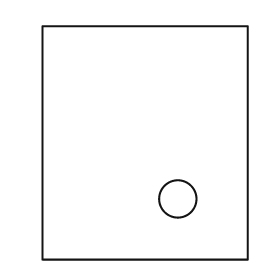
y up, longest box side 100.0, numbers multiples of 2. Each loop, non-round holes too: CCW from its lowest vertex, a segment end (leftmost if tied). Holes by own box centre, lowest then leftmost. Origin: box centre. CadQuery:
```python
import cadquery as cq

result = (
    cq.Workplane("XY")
    .moveTo(-44.0, -50.0)
    .lineTo(44.0, -50.0)
    .lineTo(44.0, 50.0)
    .lineTo(-44.0, 50.0)
    .close()
    .moveTo(14.0, -24.0)
    .circle(8.0)
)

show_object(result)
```